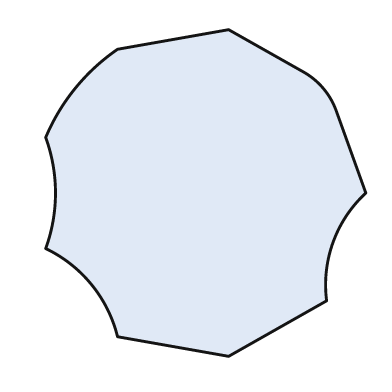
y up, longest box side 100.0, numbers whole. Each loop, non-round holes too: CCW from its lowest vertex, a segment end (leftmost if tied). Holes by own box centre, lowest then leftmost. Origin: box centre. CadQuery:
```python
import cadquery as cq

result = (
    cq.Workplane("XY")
    .moveTo(7.0, -50.0)
    .lineTo(37.0, -33.0)
    .threePointArc((39.0, -15.0), (49.0, 0.0))
    .lineTo(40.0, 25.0)
    .threePointArc((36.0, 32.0), (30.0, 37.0))
    .lineTo(7.0, 50.0)
    .lineTo(-27.0, 44.0)
    .threePointArc((-40.0, 32.0), (-49.0, 17.0))
    .threePointArc((-46.0, 0.0), (-49.0, -17.0))
    .threePointArc((-35.0, -28.0), (-27.0, -44.0))
    .close()
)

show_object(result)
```